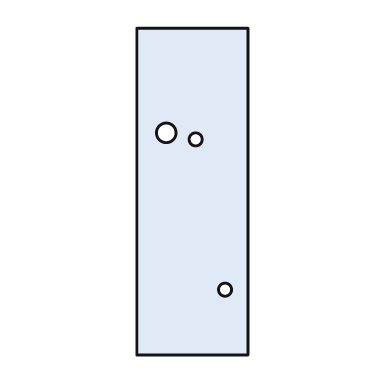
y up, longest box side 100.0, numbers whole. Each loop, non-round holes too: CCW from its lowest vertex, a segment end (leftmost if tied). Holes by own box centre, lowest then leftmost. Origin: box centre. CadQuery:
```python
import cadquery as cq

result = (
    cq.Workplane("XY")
    .moveTo(-17.0, -50.0)
    .lineTo(17.0, -50.0)
    .lineTo(17.0, 50.0)
    .lineTo(-17.0, 50.0)
    .close()
    .moveTo(10.0, -30.0)
    .circle(2.0)
    .moveTo(1.0, 16.0)
    .circle(2.0)
    .moveTo(-8.0, 18.0)
    .circle(3.0)
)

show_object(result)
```